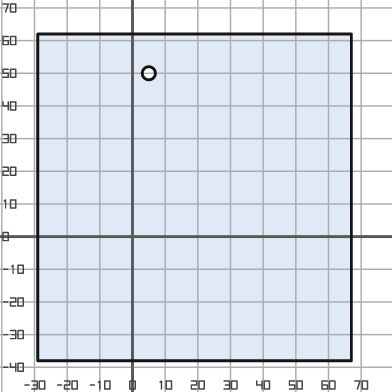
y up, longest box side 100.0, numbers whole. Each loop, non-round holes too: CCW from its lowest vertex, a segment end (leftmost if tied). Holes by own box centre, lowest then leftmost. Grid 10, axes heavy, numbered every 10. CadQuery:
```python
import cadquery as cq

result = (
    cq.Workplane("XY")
    .moveTo(-29.0, -38.0)
    .lineTo(67.0, -38.0)
    .lineTo(67.0, 62.0)
    .lineTo(-29.0, 62.0)
    .close()
    .moveTo(5.0, 50.0)
    .circle(2.0)
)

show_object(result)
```